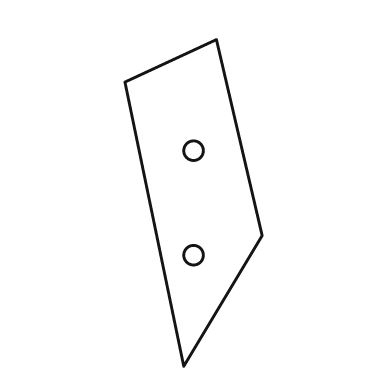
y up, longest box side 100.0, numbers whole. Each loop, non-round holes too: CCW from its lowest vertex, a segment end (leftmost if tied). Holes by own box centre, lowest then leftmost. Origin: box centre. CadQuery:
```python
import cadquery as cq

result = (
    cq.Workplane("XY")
    .moveTo(-3.0, -50.0)
    .lineTo(21.0, -10.0)
    .lineTo(7.0, 50.0)
    .lineTo(-21.0, 37.0)
    .close()
    .moveTo(0.0, -16.0)
    .circle(3.0)
    .moveTo(0.0, 16.0)
    .circle(3.0)
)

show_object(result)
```